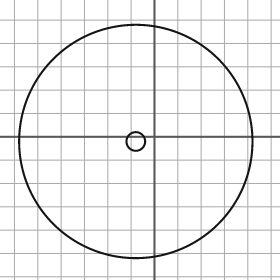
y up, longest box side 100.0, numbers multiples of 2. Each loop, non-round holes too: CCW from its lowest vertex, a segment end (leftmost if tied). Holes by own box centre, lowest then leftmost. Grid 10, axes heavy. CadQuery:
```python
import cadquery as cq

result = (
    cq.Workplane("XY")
    .moveTo(-8.0, -2.0)
    .circle(50.0)
    .moveTo(-8.0, -2.0)
    .circle(4.0)
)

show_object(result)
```